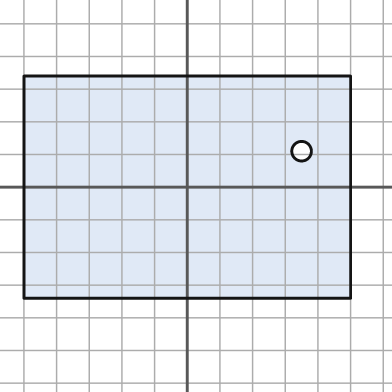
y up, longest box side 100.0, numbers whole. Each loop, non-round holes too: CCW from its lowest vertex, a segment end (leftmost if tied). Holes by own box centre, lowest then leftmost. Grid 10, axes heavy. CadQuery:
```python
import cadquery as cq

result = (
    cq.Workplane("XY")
    .moveTo(-50.0, -34.0)
    .lineTo(50.0, -34.0)
    .lineTo(50.0, 34.0)
    .lineTo(-50.0, 34.0)
    .close()
    .moveTo(35.0, 11.0)
    .circle(3.0)
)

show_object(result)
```